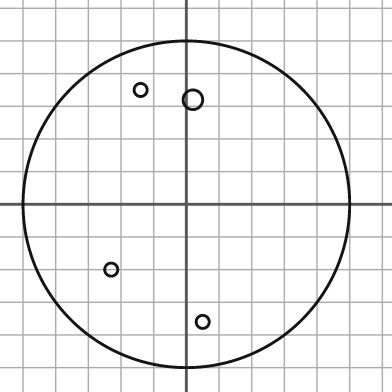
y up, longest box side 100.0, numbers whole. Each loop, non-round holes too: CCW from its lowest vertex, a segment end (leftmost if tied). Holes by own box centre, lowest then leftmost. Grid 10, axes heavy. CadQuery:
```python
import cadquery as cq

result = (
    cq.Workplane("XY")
    .moveTo(0.0, 0.0)
    .circle(50.0)
    .moveTo(5.0, -36.0)
    .circle(2.0)
    .moveTo(-23.0, -20.0)
    .circle(2.0)
    .moveTo(2.0, 32.0)
    .circle(3.0)
    .moveTo(-14.0, 35.0)
    .circle(2.0)
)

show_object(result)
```